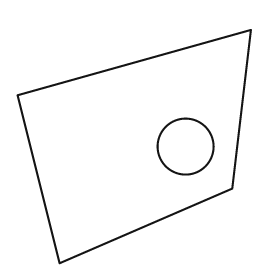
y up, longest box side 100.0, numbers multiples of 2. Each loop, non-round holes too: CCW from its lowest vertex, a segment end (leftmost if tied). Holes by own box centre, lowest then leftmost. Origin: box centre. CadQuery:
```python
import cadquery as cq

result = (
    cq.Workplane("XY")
    .moveTo(-32.0, -50.0)
    .lineTo(42.0, -18.0)
    .lineTo(50.0, 50.0)
    .lineTo(-50.0, 22.0)
    .close()
    .moveTo(22.0, 0.0)
    .circle(12.0)
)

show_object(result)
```